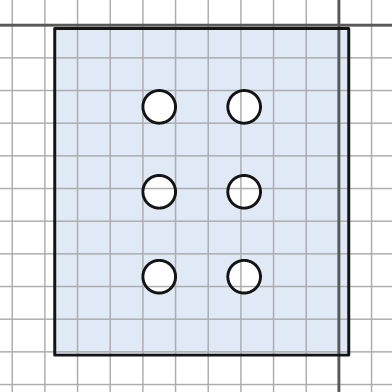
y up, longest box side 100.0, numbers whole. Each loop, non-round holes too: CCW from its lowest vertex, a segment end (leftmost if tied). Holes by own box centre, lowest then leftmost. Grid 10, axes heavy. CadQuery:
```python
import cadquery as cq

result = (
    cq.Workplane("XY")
    .moveTo(-87.0, -101.0)
    .lineTo(3.0, -101.0)
    .lineTo(3.0, -1.0)
    .lineTo(-87.0, -1.0)
    .close()
    .moveTo(-55.0, -77.0)
    .circle(5.0)
    .moveTo(-29.0, -77.0)
    .circle(5.0)
    .moveTo(-55.0, -51.0)
    .circle(5.0)
    .moveTo(-29.0, -51.0)
    .circle(5.0)
    .moveTo(-55.0, -25.0)
    .circle(5.0)
    .moveTo(-29.0, -25.0)
    .circle(5.0)
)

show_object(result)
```